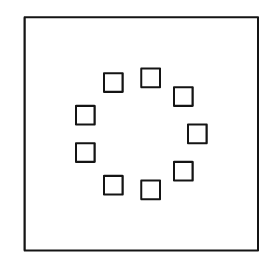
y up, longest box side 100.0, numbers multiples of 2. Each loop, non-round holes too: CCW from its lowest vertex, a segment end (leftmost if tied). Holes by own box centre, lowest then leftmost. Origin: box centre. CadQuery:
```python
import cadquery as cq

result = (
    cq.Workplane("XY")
    .moveTo(-50.0, -50.0)
    .lineTo(50.0, -50.0)
    .lineTo(50.0, 50.0)
    .lineTo(-50.0, 50.0)
    .close()
    .moveTo(0.0, -28.0)
    .lineTo(8.0, -28.0)
    .lineTo(8.0, -20.0)
    .lineTo(0.0, -20.0)
    .close()
    .moveTo(-16.0, -26.0)
    .lineTo(-8.0, -26.0)
    .lineTo(-8.0, -18.0)
    .lineTo(-16.0, -18.0)
    .close()
    .moveTo(14.0, -20.0)
    .lineTo(22.0, -20.0)
    .lineTo(22.0, -12.0)
    .lineTo(14.0, -12.0)
    .close()
    .moveTo(-28.0, -12.0)
    .lineTo(-20.0, -12.0)
    .lineTo(-20.0, -4.0)
    .lineTo(-28.0, -4.0)
    .close()
    .moveTo(20.0, -4.0)
    .lineTo(28.0, -4.0)
    .lineTo(28.0, 4.0)
    .lineTo(20.0, 4.0)
    .close()
    .moveTo(-28.0, 4.0)
    .lineTo(-20.0, 4.0)
    .lineTo(-20.0, 12.0)
    .lineTo(-28.0, 12.0)
    .close()
    .moveTo(14.0, 12.0)
    .lineTo(22.0, 12.0)
    .lineTo(22.0, 20.0)
    .lineTo(14.0, 20.0)
    .close()
    .moveTo(-16.0, 18.0)
    .lineTo(-8.0, 18.0)
    .lineTo(-8.0, 26.0)
    .lineTo(-16.0, 26.0)
    .close()
    .moveTo(0.0, 20.0)
    .lineTo(8.0, 20.0)
    .lineTo(8.0, 28.0)
    .lineTo(0.0, 28.0)
    .close()
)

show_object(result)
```